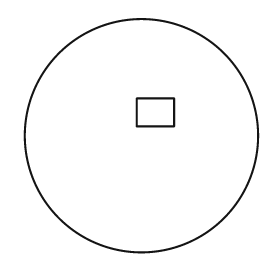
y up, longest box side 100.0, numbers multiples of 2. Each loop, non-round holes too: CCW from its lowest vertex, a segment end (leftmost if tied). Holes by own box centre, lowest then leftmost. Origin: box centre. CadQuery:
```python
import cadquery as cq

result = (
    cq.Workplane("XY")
    .moveTo(0.0, 0.0)
    .circle(50.0)
    .moveTo(-2.0, 4.0)
    .lineTo(14.0, 4.0)
    .lineTo(14.0, 16.0)
    .lineTo(-2.0, 16.0)
    .close()
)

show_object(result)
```